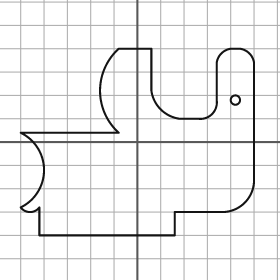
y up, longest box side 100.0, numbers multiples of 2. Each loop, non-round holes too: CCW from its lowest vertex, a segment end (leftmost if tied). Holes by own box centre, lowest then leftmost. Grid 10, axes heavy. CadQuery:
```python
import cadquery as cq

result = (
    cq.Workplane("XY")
    .moveTo(-42.0, -40.0)
    .lineTo(16.0, -40.0)
    .lineTo(16.0, -30.0)
    .lineTo(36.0, -30.0)
    .threePointArc((46.0, -26.0), (50.0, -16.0))
    .lineTo(50.0, 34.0)
    .threePointArc((48.0, 38.0), (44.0, 40.0))
    .lineTo(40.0, 40.0)
    .threePointArc((36.0, 38.0), (34.0, 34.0))
    .lineTo(34.0, 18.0)
    .threePointArc((32.0, 12.0), (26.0, 10.0))
    .lineTo(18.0, 10.0)
    .threePointArc((10.0, 14.0), (6.0, 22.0))
    .lineTo(6.0, 40.0)
    .lineTo(-8.0, 40.0)
    .threePointArc((-16.0, 22.0), (-8.0, 4.0))
    .lineTo(-50.0, 4.0)
    .threePointArc((-40.0, -12.0), (-50.0, -28.0))
    .threePointArc((-46.0, -30.0), (-42.0, -28.0))
    .close()
    .moveTo(42.0, 18.0)
    .circle(2.0)
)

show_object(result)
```